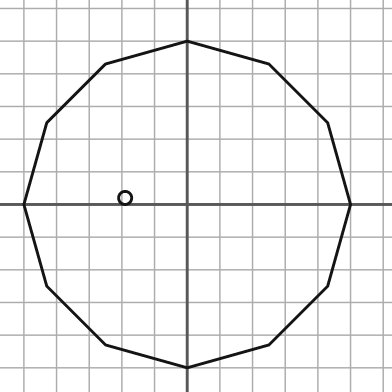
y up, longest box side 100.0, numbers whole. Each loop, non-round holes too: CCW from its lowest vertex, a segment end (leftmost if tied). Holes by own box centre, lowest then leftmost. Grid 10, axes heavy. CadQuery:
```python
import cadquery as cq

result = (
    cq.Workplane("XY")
    .moveTo(0.0, -50.0)
    .lineTo(25.0, -43.0)
    .lineTo(43.0, -25.0)
    .lineTo(50.0, 0.0)
    .lineTo(43.0, 25.0)
    .lineTo(25.0, 43.0)
    .lineTo(0.0, 50.0)
    .lineTo(-25.0, 43.0)
    .lineTo(-43.0, 25.0)
    .lineTo(-50.0, 0.0)
    .lineTo(-43.0, -25.0)
    .lineTo(-25.0, -43.0)
    .close()
    .moveTo(-19.0, 2.0)
    .circle(2.0)
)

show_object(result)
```